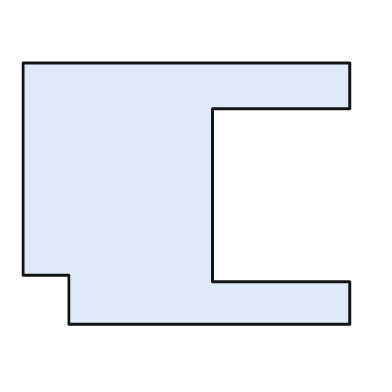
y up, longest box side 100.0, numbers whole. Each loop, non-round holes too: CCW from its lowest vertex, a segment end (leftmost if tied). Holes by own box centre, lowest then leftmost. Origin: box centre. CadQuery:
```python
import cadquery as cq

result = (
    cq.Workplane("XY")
    .moveTo(-36.0, -40.0)
    .lineTo(50.0, -40.0)
    .lineTo(50.0, -27.0)
    .lineTo(8.0, -27.0)
    .lineTo(8.0, 26.0)
    .lineTo(50.0, 26.0)
    .lineTo(50.0, 40.0)
    .lineTo(-50.0, 40.0)
    .lineTo(-50.0, -25.0)
    .lineTo(-36.0, -25.0)
    .close()
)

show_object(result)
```